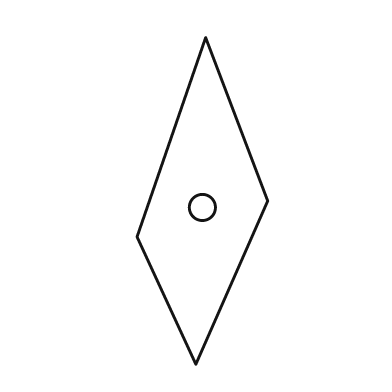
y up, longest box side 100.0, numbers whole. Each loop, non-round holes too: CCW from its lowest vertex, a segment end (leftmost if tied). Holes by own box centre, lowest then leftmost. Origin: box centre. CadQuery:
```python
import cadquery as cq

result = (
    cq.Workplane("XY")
    .moveTo(-2.0, -50.0)
    .lineTo(20.0, 0.0)
    .lineTo(1.0, 50.0)
    .lineTo(-20.0, -11.0)
    .close()
    .moveTo(0.0, -2.0)
    .circle(4.0)
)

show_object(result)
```